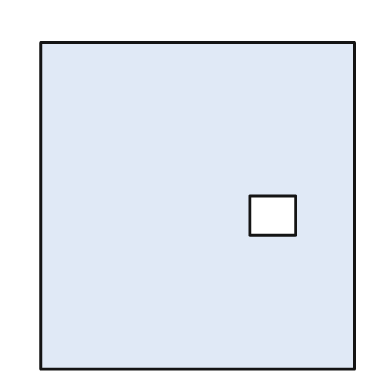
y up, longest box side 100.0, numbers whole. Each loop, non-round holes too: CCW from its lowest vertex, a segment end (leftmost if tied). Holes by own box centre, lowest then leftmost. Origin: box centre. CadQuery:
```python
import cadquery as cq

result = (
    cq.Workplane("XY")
    .moveTo(-48.0, -50.0)
    .lineTo(48.0, -50.0)
    .lineTo(48.0, 50.0)
    .lineTo(-48.0, 50.0)
    .close()
    .moveTo(16.0, -9.0)
    .lineTo(30.0, -9.0)
    .lineTo(30.0, 3.0)
    .lineTo(16.0, 3.0)
    .close()
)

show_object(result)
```